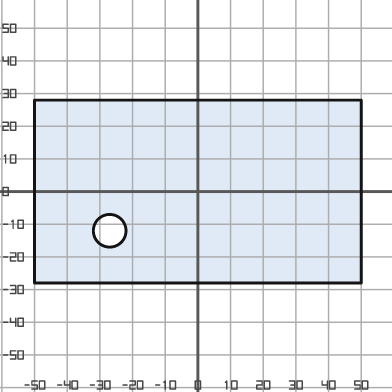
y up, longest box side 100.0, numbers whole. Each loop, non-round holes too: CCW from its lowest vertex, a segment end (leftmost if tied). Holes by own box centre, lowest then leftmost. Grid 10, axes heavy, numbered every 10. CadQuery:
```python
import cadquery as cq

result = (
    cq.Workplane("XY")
    .moveTo(-50.0, -28.0)
    .lineTo(50.0, -28.0)
    .lineTo(50.0, 28.0)
    .lineTo(-50.0, 28.0)
    .close()
    .moveTo(-27.0, -12.0)
    .circle(5.0)
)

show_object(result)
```